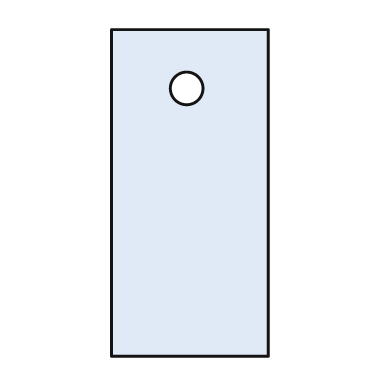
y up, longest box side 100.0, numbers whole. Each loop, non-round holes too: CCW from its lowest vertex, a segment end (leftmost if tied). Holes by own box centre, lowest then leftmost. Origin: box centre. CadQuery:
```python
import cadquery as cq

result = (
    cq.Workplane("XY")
    .moveTo(-24.0, -50.0)
    .lineTo(24.0, -50.0)
    .lineTo(24.0, 50.0)
    .lineTo(-24.0, 50.0)
    .close()
    .moveTo(-1.0, 32.0)
    .circle(5.0)
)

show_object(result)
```